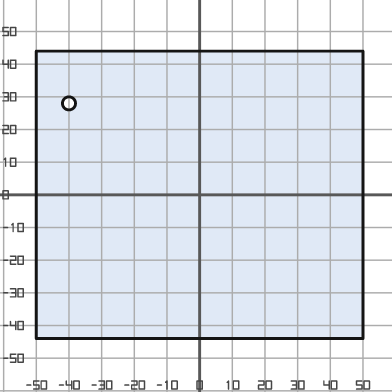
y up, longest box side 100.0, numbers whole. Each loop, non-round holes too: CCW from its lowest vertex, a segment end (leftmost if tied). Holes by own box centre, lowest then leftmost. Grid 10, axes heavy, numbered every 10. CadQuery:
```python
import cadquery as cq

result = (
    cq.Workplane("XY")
    .moveTo(-50.0, -44.0)
    .lineTo(50.0, -44.0)
    .lineTo(50.0, 44.0)
    .lineTo(-50.0, 44.0)
    .close()
    .moveTo(-40.0, 28.0)
    .circle(2.0)
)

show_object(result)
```